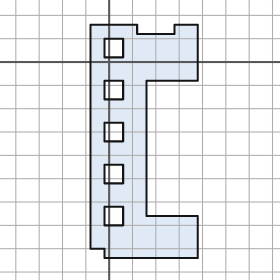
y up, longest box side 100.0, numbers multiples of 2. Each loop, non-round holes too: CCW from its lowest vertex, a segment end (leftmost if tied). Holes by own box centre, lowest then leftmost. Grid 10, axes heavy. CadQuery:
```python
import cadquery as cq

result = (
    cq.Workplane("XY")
    .moveTo(-2.0, -84.0)
    .lineTo(38.0, -84.0)
    .lineTo(38.0, -66.0)
    .lineTo(16.0, -66.0)
    .lineTo(16.0, -8.0)
    .lineTo(38.0, -8.0)
    .lineTo(38.0, 16.0)
    .lineTo(28.0, 16.0)
    .lineTo(28.0, 12.0)
    .lineTo(12.0, 12.0)
    .lineTo(12.0, 16.0)
    .lineTo(-8.0, 16.0)
    .lineTo(-8.0, -80.0)
    .lineTo(-2.0, -80.0)
    .close()
    .moveTo(-2.0, -70.0)
    .lineTo(6.0, -70.0)
    .lineTo(6.0, -62.0)
    .lineTo(-2.0, -62.0)
    .close()
    .moveTo(-2.0, -52.0)
    .lineTo(6.0, -52.0)
    .lineTo(6.0, -44.0)
    .lineTo(-2.0, -44.0)
    .close()
    .moveTo(-2.0, -34.0)
    .lineTo(6.0, -34.0)
    .lineTo(6.0, -26.0)
    .lineTo(-2.0, -26.0)
    .close()
    .moveTo(-2.0, -16.0)
    .lineTo(6.0, -16.0)
    .lineTo(6.0, -8.0)
    .lineTo(-2.0, -8.0)
    .close()
    .moveTo(-2.0, 2.0)
    .lineTo(6.0, 2.0)
    .lineTo(6.0, 10.0)
    .lineTo(-2.0, 10.0)
    .close()
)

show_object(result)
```